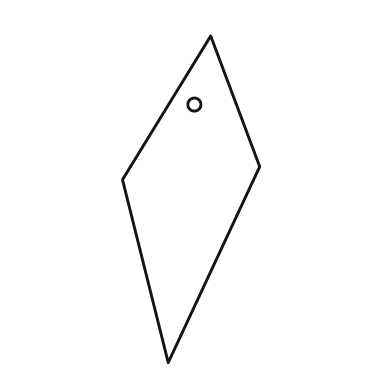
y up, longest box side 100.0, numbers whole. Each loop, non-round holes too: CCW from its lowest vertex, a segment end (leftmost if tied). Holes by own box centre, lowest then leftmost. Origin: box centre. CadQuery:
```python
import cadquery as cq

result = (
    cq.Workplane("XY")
    .moveTo(-7.0, -50.0)
    .lineTo(21.0, 10.0)
    .lineTo(6.0, 50.0)
    .lineTo(-21.0, 6.0)
    .close()
    .moveTo(1.0, 29.0)
    .circle(2.0)
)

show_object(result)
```